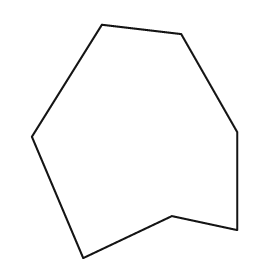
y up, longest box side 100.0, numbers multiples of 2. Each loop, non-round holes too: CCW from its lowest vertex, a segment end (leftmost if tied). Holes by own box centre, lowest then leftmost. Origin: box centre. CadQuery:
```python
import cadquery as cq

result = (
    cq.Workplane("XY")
    .moveTo(-22.0, -50.0)
    .lineTo(16.0, -32.0)
    .lineTo(44.0, -38.0)
    .lineTo(44.0, 4.0)
    .lineTo(20.0, 46.0)
    .lineTo(-14.0, 50.0)
    .lineTo(-44.0, 2.0)
    .close()
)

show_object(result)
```